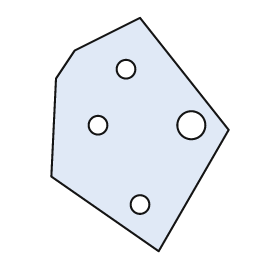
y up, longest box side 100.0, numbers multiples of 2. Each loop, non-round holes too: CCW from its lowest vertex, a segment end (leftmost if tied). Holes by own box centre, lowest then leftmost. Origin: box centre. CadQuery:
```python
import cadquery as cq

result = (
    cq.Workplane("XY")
    .moveTo(8.0, -50.0)
    .lineTo(38.0, 2.0)
    .lineTo(0.0, 50.0)
    .lineTo(-28.0, 36.0)
    .lineTo(-36.0, 24.0)
    .lineTo(-38.0, -18.0)
    .close()
    .moveTo(0.0, -30.0)
    .circle(4.0)
    .moveTo(-18.0, 4.0)
    .circle(4.0)
    .moveTo(22.0, 4.0)
    .circle(6.0)
    .moveTo(-6.0, 28.0)
    .circle(4.0)
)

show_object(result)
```